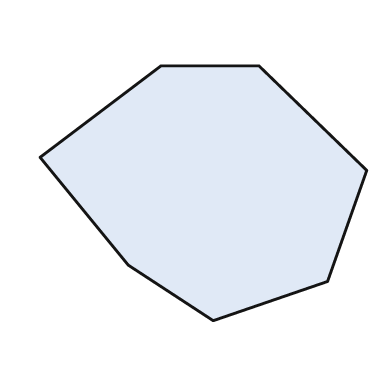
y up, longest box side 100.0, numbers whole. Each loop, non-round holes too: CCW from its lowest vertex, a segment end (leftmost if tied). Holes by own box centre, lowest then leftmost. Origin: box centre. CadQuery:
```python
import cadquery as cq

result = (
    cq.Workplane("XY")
    .moveTo(3.0, -39.0)
    .lineTo(38.0, -27.0)
    .lineTo(50.0, 7.0)
    .lineTo(17.0, 39.0)
    .lineTo(-13.0, 39.0)
    .lineTo(-50.0, 11.0)
    .lineTo(-23.0, -22.0)
    .close()
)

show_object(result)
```